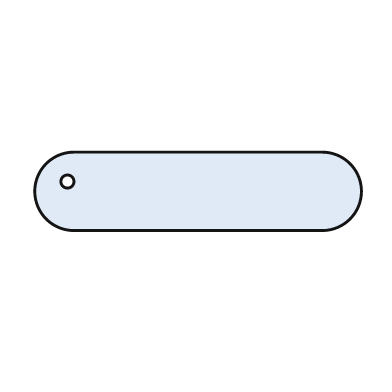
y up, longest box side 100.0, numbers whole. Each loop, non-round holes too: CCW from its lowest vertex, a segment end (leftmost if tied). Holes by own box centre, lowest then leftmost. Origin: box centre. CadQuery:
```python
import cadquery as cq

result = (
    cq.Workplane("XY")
    .moveTo(-38.0, -12.0)
    .lineTo(38.0, -12.0)
    .threePointArc((50.0, 0.0), (38.0, 12.0))
    .lineTo(-38.0, 12.0)
    .threePointArc((-50.0, 0.0), (-38.0, -12.0))
    .close()
    .moveTo(-40.0, 3.0)
    .circle(2.0)
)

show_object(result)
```